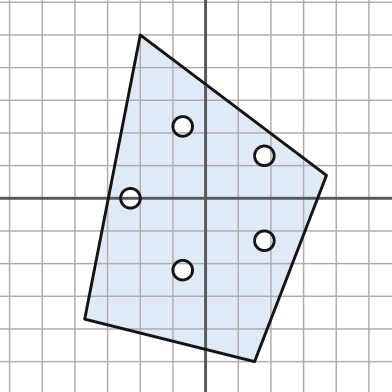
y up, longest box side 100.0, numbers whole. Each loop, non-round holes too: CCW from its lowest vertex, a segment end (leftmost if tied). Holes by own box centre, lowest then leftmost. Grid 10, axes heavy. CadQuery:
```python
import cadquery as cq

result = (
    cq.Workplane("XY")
    .moveTo(15.0, -50.0)
    .lineTo(37.0, 7.0)
    .lineTo(-20.0, 50.0)
    .lineTo(-37.0, -37.0)
    .close()
    .moveTo(-7.0, -22.0)
    .circle(3.0)
    .moveTo(18.0, -13.0)
    .circle(3.0)
    .moveTo(-23.0, 0.0)
    .circle(3.0)
    .moveTo(18.0, 13.0)
    .circle(3.0)
    .moveTo(-7.0, 22.0)
    .circle(3.0)
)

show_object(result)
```